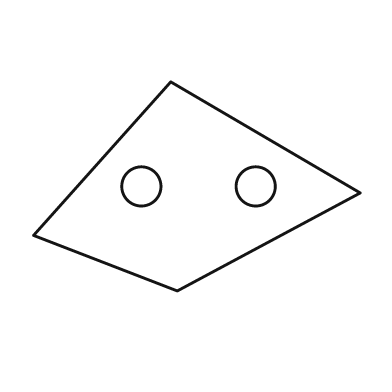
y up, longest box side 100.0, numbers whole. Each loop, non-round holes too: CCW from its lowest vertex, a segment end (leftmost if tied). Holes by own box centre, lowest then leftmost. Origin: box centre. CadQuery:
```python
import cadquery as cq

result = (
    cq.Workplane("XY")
    .moveTo(-6.0, -32.0)
    .lineTo(50.0, -2.0)
    .lineTo(-8.0, 32.0)
    .lineTo(-50.0, -15.0)
    .close()
    .moveTo(-17.0, 0.0)
    .circle(6.0)
    .moveTo(18.0, 0.0)
    .circle(6.0)
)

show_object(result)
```